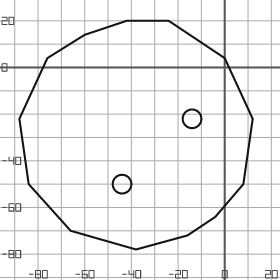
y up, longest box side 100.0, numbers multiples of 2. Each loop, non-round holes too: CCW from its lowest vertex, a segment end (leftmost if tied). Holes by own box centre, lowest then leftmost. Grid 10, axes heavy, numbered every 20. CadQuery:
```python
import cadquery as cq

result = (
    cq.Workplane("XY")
    .moveTo(-38.0, -78.0)
    .lineTo(-16.0, -72.0)
    .lineTo(-4.0, -64.0)
    .lineTo(8.0, -50.0)
    .lineTo(12.0, -22.0)
    .lineTo(0.0, 4.0)
    .lineTo(-24.0, 20.0)
    .lineTo(-42.0, 20.0)
    .lineTo(-60.0, 14.0)
    .lineTo(-76.0, 4.0)
    .lineTo(-88.0, -22.0)
    .lineTo(-84.0, -50.0)
    .lineTo(-66.0, -70.0)
    .close()
    .moveTo(-44.0, -50.0)
    .circle(4.0)
    .moveTo(-14.0, -22.0)
    .circle(4.0)
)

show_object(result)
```